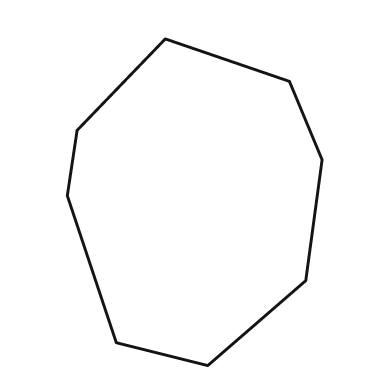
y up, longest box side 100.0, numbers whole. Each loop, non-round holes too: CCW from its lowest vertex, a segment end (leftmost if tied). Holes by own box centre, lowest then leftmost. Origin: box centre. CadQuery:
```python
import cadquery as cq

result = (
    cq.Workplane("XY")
    .moveTo(4.0, -50.0)
    .lineTo(34.0, -24.0)
    .lineTo(39.0, 13.0)
    .lineTo(29.0, 37.0)
    .lineTo(-9.0, 50.0)
    .lineTo(-36.0, 22.0)
    .lineTo(-39.0, 2.0)
    .lineTo(-24.0, -43.0)
    .close()
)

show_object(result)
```